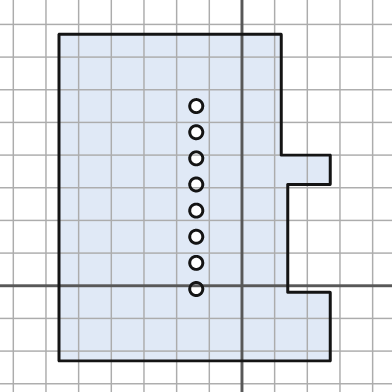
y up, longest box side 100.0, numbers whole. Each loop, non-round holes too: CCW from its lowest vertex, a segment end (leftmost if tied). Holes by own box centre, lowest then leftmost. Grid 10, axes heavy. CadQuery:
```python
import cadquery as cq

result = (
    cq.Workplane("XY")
    .moveTo(-56.0, -23.0)
    .lineTo(27.0, -23.0)
    .lineTo(27.0, -2.0)
    .lineTo(14.0, -2.0)
    .lineTo(14.0, 31.0)
    .lineTo(27.0, 31.0)
    .lineTo(27.0, 40.0)
    .lineTo(12.0, 40.0)
    .lineTo(12.0, 77.0)
    .lineTo(-56.0, 77.0)
    .close()
    .moveTo(-14.0, -1.0)
    .circle(2.0)
    .moveTo(-14.0, 7.0)
    .circle(2.0)
    .moveTo(-14.0, 15.0)
    .circle(2.0)
    .moveTo(-14.0, 23.0)
    .circle(2.0)
    .moveTo(-14.0, 31.0)
    .circle(2.0)
    .moveTo(-14.0, 39.0)
    .circle(2.0)
    .moveTo(-14.0, 47.0)
    .circle(2.0)
    .moveTo(-14.0, 55.0)
    .circle(2.0)
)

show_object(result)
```